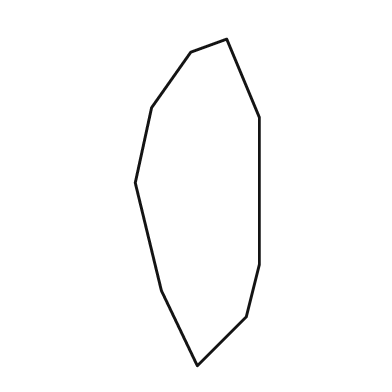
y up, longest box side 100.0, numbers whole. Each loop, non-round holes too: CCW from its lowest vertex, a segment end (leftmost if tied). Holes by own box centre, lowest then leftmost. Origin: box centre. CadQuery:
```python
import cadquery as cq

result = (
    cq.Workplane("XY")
    .moveTo(0.0, -50.0)
    .lineTo(15.0, -35.0)
    .lineTo(19.0, -19.0)
    .lineTo(19.0, 26.0)
    .lineTo(9.0, 50.0)
    .lineTo(-2.0, 46.0)
    .lineTo(-14.0, 29.0)
    .lineTo(-19.0, 6.0)
    .lineTo(-11.0, -27.0)
    .close()
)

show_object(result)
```